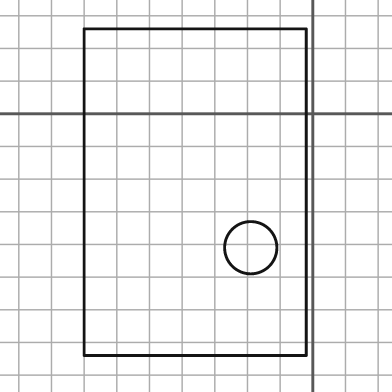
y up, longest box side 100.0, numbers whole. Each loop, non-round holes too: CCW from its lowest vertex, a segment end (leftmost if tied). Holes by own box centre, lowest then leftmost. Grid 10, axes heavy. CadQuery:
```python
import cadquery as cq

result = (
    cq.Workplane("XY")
    .moveTo(-70.0, -74.0)
    .lineTo(-2.0, -74.0)
    .lineTo(-2.0, 26.0)
    .lineTo(-70.0, 26.0)
    .close()
    .moveTo(-19.0, -41.0)
    .circle(8.0)
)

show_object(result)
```